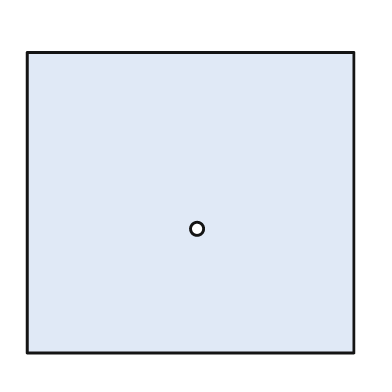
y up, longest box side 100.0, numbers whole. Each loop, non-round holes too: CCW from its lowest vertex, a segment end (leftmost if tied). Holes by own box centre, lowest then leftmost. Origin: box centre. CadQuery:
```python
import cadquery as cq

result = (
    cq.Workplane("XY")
    .moveTo(-50.0, -46.0)
    .lineTo(50.0, -46.0)
    .lineTo(50.0, 46.0)
    .lineTo(-50.0, 46.0)
    .close()
    .moveTo(2.0, -8.0)
    .circle(2.0)
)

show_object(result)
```